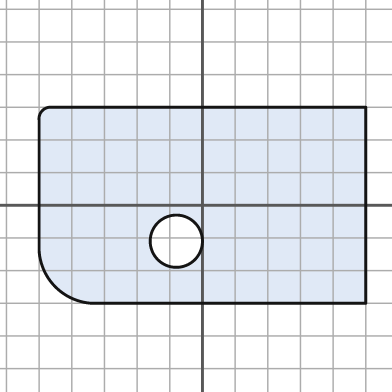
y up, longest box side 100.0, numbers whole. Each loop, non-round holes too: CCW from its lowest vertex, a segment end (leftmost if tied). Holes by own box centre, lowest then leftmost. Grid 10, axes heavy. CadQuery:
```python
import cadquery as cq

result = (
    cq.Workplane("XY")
    .moveTo(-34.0, -30.0)
    .lineTo(50.0, -30.0)
    .lineTo(50.0, 30.0)
    .lineTo(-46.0, 30.0)
    .threePointArc((-49.0, 29.0), (-50.0, 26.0))
    .lineTo(-50.0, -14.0)
    .threePointArc((-45.0, -25.0), (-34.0, -30.0))
    .close()
    .moveTo(-8.0, -11.0)
    .circle(8.0)
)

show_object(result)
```